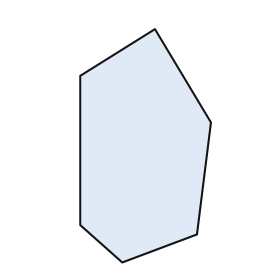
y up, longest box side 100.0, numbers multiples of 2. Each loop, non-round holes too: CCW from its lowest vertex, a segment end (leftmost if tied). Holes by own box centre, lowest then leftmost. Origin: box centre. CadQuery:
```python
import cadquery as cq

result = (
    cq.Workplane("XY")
    .moveTo(-10.0, -50.0)
    .lineTo(22.0, -38.0)
    .lineTo(28.0, 10.0)
    .lineTo(4.0, 50.0)
    .lineTo(-28.0, 30.0)
    .lineTo(-28.0, -34.0)
    .close()
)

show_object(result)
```